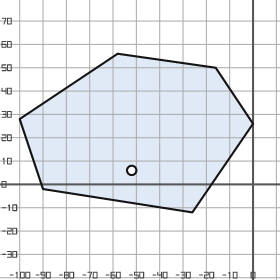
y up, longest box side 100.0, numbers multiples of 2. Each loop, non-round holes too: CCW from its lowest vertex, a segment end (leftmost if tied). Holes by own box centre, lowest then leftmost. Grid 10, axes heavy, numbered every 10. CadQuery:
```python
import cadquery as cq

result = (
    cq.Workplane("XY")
    .moveTo(-26.0, -12.0)
    .lineTo(0.0, 26.0)
    .lineTo(-16.0, 50.0)
    .lineTo(-58.0, 56.0)
    .lineTo(-100.0, 28.0)
    .lineTo(-90.0, -2.0)
    .close()
    .moveTo(-52.0, 6.0)
    .circle(2.0)
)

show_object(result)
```